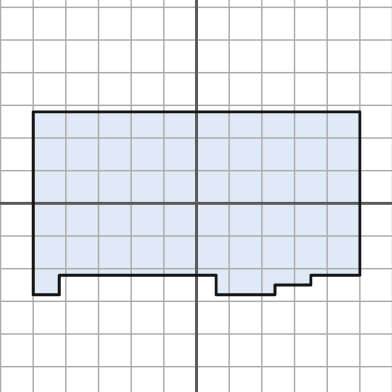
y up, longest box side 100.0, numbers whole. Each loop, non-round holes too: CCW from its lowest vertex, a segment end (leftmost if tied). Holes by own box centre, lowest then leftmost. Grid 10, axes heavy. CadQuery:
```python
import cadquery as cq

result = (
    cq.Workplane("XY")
    .moveTo(-50.0, -28.0)
    .lineTo(-42.0, -28.0)
    .lineTo(-42.0, -22.0)
    .lineTo(6.0, -22.0)
    .lineTo(6.0, -28.0)
    .lineTo(24.0, -28.0)
    .lineTo(24.0, -25.0)
    .lineTo(35.0, -25.0)
    .lineTo(35.0, -22.0)
    .lineTo(50.0, -22.0)
    .lineTo(50.0, 28.0)
    .lineTo(-50.0, 28.0)
    .close()
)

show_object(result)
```